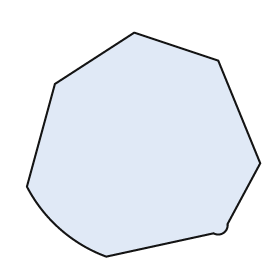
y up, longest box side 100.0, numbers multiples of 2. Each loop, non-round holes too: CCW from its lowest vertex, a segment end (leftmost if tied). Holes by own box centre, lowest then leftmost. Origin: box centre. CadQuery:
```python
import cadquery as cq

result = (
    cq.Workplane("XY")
    .moveTo(-16.0, -48.0)
    .lineTo(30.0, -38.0)
    .threePointArc((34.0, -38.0), (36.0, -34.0))
    .lineTo(50.0, -8.0)
    .lineTo(32.0, 36.0)
    .lineTo(-4.0, 48.0)
    .lineTo(-38.0, 26.0)
    .lineTo(-50.0, -18.0)
    .threePointArc((-36.0, -36.0), (-16.0, -48.0))
    .close()
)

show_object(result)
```